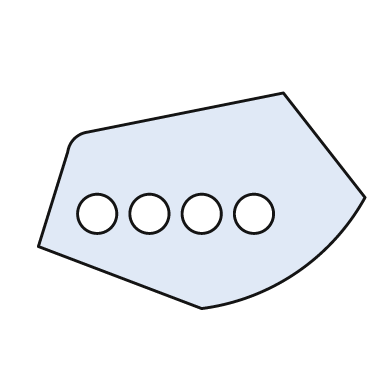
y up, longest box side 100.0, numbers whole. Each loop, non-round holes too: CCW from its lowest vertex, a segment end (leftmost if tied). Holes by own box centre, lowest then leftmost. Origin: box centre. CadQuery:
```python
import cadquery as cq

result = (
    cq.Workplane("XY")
    .moveTo(0.0, -33.0)
    .threePointArc((29.0, -22.0), (50.0, 1.0))
    .lineTo(25.0, 33.0)
    .lineTo(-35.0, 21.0)
    .threePointArc((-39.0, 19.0), (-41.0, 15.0))
    .lineTo(-50.0, -14.0)
    .close()
    .moveTo(-32.0, -4.0)
    .circle(6.0)
    .moveTo(-16.0, -4.0)
    .circle(6.0)
    .moveTo(0.0, -4.0)
    .circle(6.0)
    .moveTo(16.0, -4.0)
    .circle(6.0)
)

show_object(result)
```